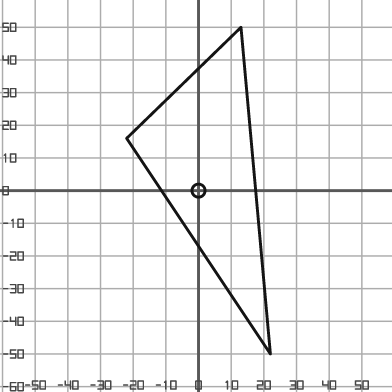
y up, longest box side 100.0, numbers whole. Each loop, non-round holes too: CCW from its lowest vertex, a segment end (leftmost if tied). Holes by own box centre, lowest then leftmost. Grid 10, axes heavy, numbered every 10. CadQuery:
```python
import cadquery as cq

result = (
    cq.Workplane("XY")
    .moveTo(22.0, -50.0)
    .lineTo(13.0, 50.0)
    .lineTo(-22.0, 16.0)
    .close()
    .moveTo(0.0, 0.0)
    .circle(2.0)
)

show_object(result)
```